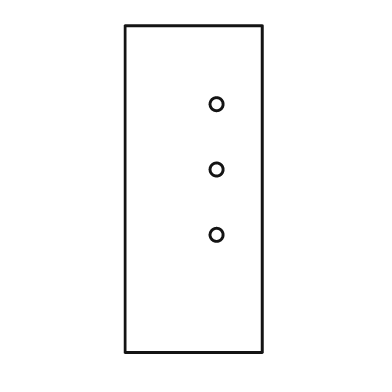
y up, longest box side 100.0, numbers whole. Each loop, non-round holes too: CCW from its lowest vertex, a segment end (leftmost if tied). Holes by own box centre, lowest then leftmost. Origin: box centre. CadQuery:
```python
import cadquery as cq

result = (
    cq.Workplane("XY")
    .moveTo(-21.0, -50.0)
    .lineTo(21.0, -50.0)
    .lineTo(21.0, 50.0)
    .lineTo(-21.0, 50.0)
    .close()
    .moveTo(7.0, -14.0)
    .circle(2.0)
    .moveTo(7.0, 6.0)
    .circle(2.0)
    .moveTo(7.0, 26.0)
    .circle(2.0)
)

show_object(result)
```